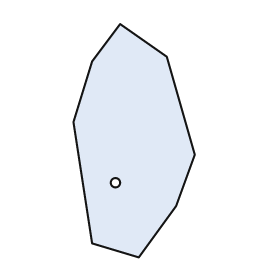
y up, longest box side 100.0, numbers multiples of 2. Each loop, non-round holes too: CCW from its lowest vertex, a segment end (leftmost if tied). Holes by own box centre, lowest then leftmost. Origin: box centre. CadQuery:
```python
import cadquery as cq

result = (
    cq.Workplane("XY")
    .moveTo(2.0, -50.0)
    .lineTo(18.0, -28.0)
    .lineTo(26.0, -6.0)
    .lineTo(14.0, 36.0)
    .lineTo(-6.0, 50.0)
    .lineTo(-18.0, 34.0)
    .lineTo(-26.0, 8.0)
    .lineTo(-18.0, -44.0)
    .close()
    .moveTo(-8.0, -18.0)
    .circle(2.0)
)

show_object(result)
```